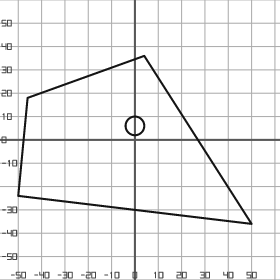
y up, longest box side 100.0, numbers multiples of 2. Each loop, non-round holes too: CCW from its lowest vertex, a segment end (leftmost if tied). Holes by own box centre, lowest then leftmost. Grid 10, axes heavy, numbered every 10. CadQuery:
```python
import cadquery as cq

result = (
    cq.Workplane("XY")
    .moveTo(50.0, -36.0)
    .lineTo(4.0, 36.0)
    .lineTo(-46.0, 18.0)
    .lineTo(-50.0, -24.0)
    .close()
    .moveTo(0.0, 6.0)
    .circle(4.0)
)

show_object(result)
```